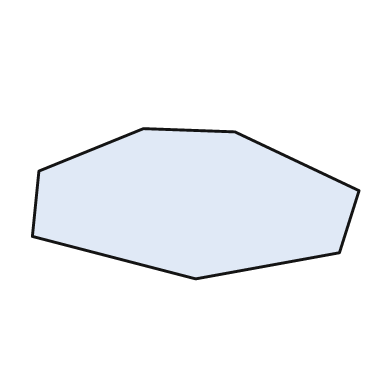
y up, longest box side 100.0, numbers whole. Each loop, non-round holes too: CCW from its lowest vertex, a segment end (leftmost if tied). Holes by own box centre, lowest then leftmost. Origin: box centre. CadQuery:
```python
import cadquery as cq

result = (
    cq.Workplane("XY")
    .moveTo(0.0, -23.0)
    .lineTo(44.0, -15.0)
    .lineTo(50.0, 4.0)
    .lineTo(12.0, 22.0)
    .lineTo(-16.0, 23.0)
    .lineTo(-48.0, 10.0)
    .lineTo(-50.0, -10.0)
    .close()
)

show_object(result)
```